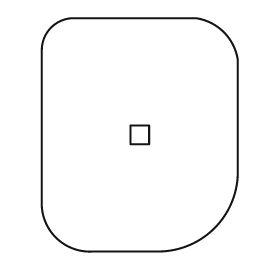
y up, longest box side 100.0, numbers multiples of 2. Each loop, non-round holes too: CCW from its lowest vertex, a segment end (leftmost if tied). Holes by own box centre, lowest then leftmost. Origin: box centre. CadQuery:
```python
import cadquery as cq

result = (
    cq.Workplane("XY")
    .moveTo(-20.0, -50.0)
    .lineTo(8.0, -50.0)
    .threePointArc((32.0, -40.0), (42.0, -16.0))
    .lineTo(42.0, 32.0)
    .threePointArc((36.0, 44.0), (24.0, 50.0))
    .lineTo(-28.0, 50.0)
    .threePointArc((-38.0, 46.0), (-42.0, 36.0))
    .lineTo(-42.0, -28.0)
    .threePointArc((-36.0, -44.0), (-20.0, -50.0))
    .close()
    .moveTo(-4.0, -4.0)
    .lineTo(4.0, -4.0)
    .lineTo(4.0, 4.0)
    .lineTo(-4.0, 4.0)
    .close()
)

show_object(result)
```